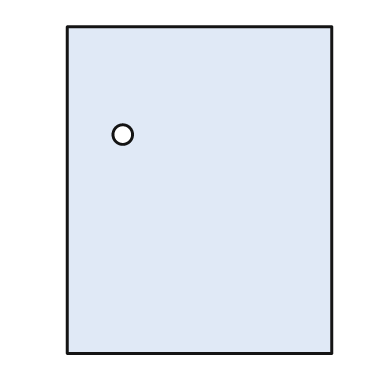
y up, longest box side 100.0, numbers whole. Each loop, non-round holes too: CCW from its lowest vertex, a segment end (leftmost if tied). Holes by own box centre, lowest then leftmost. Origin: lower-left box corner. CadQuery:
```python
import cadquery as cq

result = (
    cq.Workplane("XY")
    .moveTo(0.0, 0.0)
    .lineTo(81.0, 0.0)
    .lineTo(81.0, 100.0)
    .lineTo(0.0, 100.0)
    .close()
    .moveTo(17.0, 67.0)
    .circle(3.0)
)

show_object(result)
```